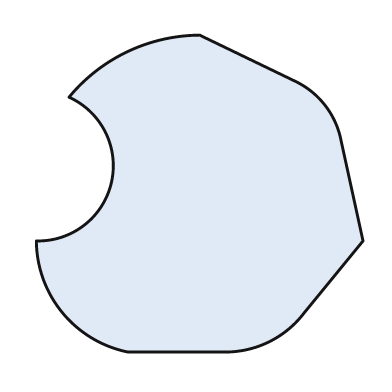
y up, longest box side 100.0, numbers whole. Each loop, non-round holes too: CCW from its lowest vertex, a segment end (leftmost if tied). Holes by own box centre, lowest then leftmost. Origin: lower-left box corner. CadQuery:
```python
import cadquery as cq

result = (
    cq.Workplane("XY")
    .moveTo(28.0, 0.0)
    .lineTo(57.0, 0.0)
    .threePointArc((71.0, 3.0), (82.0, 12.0))
    .lineTo(100.0, 34.0)
    .lineTo(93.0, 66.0)
    .threePointArc((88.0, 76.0), (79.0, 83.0))
    .lineTo(50.0, 97.0)
    .threePointArc((28.0, 92.0), (10.0, 78.0))
    .threePointArc((23.0, 52.0), (0.0, 34.0))
    .threePointArc((8.0, 12.0), (28.0, 0.0))
    .close()
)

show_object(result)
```